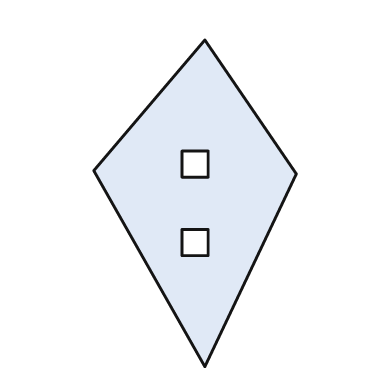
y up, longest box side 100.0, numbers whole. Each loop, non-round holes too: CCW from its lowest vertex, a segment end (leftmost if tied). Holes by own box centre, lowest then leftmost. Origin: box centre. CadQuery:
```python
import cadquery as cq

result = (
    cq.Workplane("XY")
    .moveTo(3.0, -50.0)
    .lineTo(31.0, 9.0)
    .lineTo(3.0, 50.0)
    .lineTo(-31.0, 10.0)
    .close()
    .moveTo(-4.0, -16.0)
    .lineTo(4.0, -16.0)
    .lineTo(4.0, -8.0)
    .lineTo(-4.0, -8.0)
    .close()
    .moveTo(-4.0, 8.0)
    .lineTo(4.0, 8.0)
    .lineTo(4.0, 16.0)
    .lineTo(-4.0, 16.0)
    .close()
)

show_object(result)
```